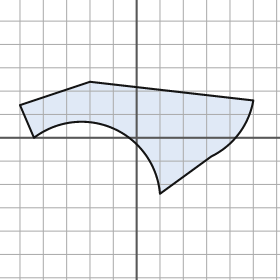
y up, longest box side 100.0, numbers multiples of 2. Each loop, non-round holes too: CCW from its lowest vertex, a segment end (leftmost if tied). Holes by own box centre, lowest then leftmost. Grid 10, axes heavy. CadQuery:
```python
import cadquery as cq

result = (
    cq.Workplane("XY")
    .moveTo(10.0, -24.0)
    .lineTo(32.0, -8.0)
    .threePointArc((44.0, 2.0), (50.0, 16.0))
    .lineTo(-20.0, 24.0)
    .lineTo(-50.0, 14.0)
    .lineTo(-44.0, 0.0)
    .threePointArc((-10.0, 4.0), (10.0, -24.0))
    .close()
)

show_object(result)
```